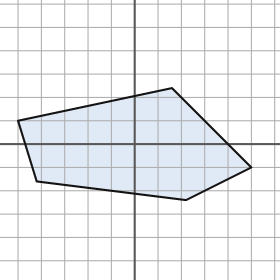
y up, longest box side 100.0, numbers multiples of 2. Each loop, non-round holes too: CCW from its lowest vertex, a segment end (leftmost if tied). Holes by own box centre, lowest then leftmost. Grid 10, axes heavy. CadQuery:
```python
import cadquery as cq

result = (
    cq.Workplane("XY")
    .moveTo(22.0, -24.0)
    .lineTo(50.0, -10.0)
    .lineTo(16.0, 24.0)
    .lineTo(-50.0, 10.0)
    .lineTo(-42.0, -16.0)
    .close()
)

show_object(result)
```